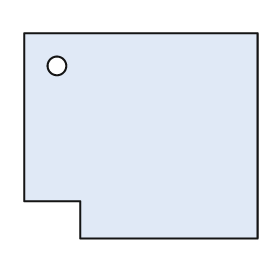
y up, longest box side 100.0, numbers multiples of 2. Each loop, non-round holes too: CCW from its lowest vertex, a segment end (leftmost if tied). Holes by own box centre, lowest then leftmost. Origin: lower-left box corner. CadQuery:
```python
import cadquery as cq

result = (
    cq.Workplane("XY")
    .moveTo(24.0, 0.0)
    .lineTo(100.0, 0.0)
    .lineTo(100.0, 88.0)
    .lineTo(0.0, 88.0)
    .lineTo(0.0, 16.0)
    .lineTo(24.0, 16.0)
    .close()
    .moveTo(14.0, 74.0)
    .circle(4.0)
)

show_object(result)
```